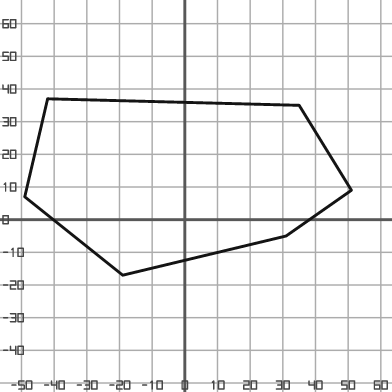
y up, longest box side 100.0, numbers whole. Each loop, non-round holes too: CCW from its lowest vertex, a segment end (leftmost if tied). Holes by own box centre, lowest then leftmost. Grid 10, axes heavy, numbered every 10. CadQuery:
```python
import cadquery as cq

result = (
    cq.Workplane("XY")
    .moveTo(-19.0, -17.0)
    .lineTo(31.0, -5.0)
    .lineTo(51.0, 9.0)
    .lineTo(35.0, 35.0)
    .lineTo(-42.0, 37.0)
    .lineTo(-49.0, 7.0)
    .close()
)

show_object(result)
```